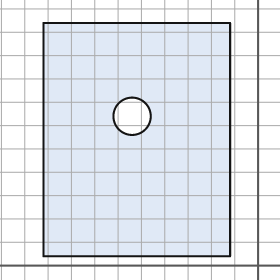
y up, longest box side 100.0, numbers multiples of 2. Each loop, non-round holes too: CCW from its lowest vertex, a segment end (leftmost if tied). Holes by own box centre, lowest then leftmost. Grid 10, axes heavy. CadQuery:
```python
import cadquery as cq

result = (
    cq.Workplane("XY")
    .moveTo(-92.0, 4.0)
    .lineTo(-12.0, 4.0)
    .lineTo(-12.0, 104.0)
    .lineTo(-92.0, 104.0)
    .close()
    .moveTo(-54.0, 64.0)
    .circle(8.0)
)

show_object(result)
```